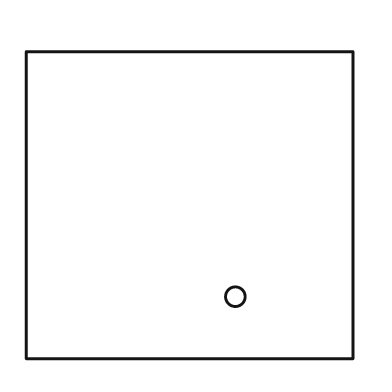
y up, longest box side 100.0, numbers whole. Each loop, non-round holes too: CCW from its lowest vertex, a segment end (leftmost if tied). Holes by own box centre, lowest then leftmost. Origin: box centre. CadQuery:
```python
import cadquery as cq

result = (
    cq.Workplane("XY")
    .moveTo(-50.0, -47.0)
    .lineTo(50.0, -47.0)
    .lineTo(50.0, 47.0)
    .lineTo(-50.0, 47.0)
    .close()
    .moveTo(14.0, -28.0)
    .circle(3.0)
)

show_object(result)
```